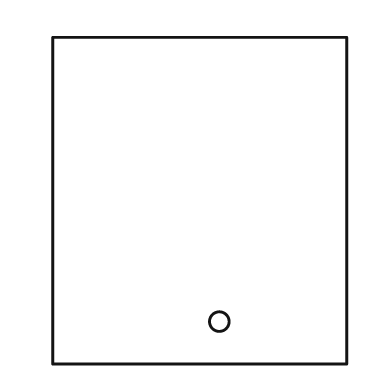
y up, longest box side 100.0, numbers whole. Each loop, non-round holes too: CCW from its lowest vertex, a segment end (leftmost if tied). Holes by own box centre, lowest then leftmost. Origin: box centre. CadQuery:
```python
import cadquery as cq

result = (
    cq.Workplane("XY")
    .moveTo(-45.0, -50.0)
    .lineTo(45.0, -50.0)
    .lineTo(45.0, 50.0)
    .lineTo(-45.0, 50.0)
    .close()
    .moveTo(6.0, -37.0)
    .circle(3.0)
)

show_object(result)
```